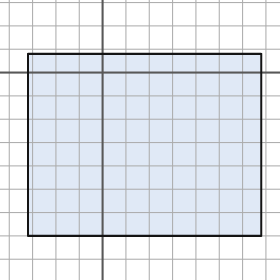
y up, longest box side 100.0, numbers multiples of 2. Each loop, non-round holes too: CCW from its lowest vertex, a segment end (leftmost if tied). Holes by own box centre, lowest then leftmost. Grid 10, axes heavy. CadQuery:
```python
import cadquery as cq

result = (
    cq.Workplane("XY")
    .moveTo(-32.0, -70.0)
    .lineTo(68.0, -70.0)
    .lineTo(68.0, 8.0)
    .lineTo(-32.0, 8.0)
    .close()
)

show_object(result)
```